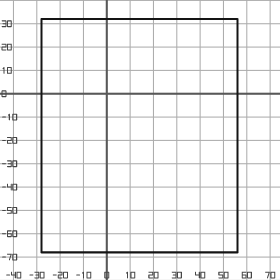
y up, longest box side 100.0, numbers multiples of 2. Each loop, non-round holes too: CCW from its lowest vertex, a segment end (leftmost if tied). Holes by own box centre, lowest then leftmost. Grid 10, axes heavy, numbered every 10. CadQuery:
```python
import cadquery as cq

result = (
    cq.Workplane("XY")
    .moveTo(-28.0, -68.0)
    .lineTo(56.0, -68.0)
    .lineTo(56.0, 32.0)
    .lineTo(-28.0, 32.0)
    .close()
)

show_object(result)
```